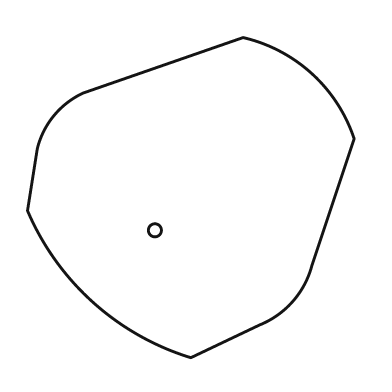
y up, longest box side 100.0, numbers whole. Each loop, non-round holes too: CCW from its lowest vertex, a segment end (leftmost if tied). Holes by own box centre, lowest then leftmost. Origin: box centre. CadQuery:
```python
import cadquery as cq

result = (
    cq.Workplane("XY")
    .moveTo(0.0, -49.0)
    .lineTo(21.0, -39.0)
    .threePointArc((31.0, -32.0), (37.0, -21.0))
    .lineTo(50.0, 18.0)
    .threePointArc((37.0, 38.0), (16.0, 49.0))
    .lineTo(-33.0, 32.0)
    .threePointArc((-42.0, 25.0), (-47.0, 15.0))
    .lineTo(-50.0, -4.0)
    .threePointArc((-30.0, -32.0), (0.0, -49.0))
    .close()
    .moveTo(-11.0, -10.0)
    .circle(2.0)
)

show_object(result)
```